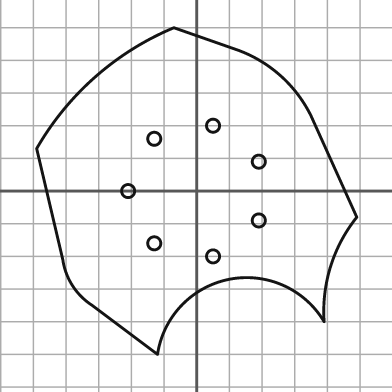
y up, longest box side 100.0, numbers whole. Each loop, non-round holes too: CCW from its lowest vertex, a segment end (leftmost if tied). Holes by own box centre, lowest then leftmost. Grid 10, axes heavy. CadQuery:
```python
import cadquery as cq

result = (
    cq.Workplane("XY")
    .moveTo(-12.0, -50.0)
    .threePointArc((10.0, -27.0), (39.0, -40.0))
    .threePointArc((41.0, -23.0), (49.0, -8.0))
    .lineTo(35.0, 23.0)
    .threePointArc((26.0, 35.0), (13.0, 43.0))
    .lineTo(-7.0, 50.0)
    .threePointArc((-31.0, 35.0), (-49.0, 13.0))
    .lineTo(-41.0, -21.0)
    .threePointArc((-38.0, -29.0), (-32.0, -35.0))
    .close()
    .moveTo(5.0, -20.0)
    .circle(2.0)
    .moveTo(-13.0, -16.0)
    .circle(2.0)
    .moveTo(19.0, -9.0)
    .circle(2.0)
    .moveTo(-21.0, 0.0)
    .circle(2.0)
    .moveTo(19.0, 9.0)
    .circle(2.0)
    .moveTo(-13.0, 16.0)
    .circle(2.0)
    .moveTo(5.0, 20.0)
    .circle(2.0)
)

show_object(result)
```